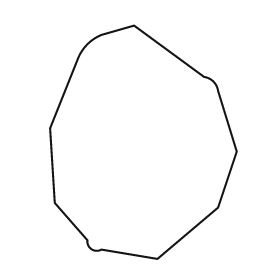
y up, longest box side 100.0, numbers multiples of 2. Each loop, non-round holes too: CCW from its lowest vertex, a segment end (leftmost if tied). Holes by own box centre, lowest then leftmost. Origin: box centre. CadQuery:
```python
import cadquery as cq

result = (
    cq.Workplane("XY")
    .moveTo(6.0, -50.0)
    .lineTo(32.0, -28.0)
    .lineTo(40.0, -4.0)
    .lineTo(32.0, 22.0)
    .threePointArc((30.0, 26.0), (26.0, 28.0))
    .lineTo(-4.0, 50.0)
    .lineTo(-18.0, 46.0)
    .threePointArc((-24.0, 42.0), (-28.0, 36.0))
    .lineTo(-40.0, 6.0)
    .lineTo(-38.0, -26.0)
    .lineTo(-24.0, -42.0)
    .threePointArc((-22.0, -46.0), (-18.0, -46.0))
    .close()
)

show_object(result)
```